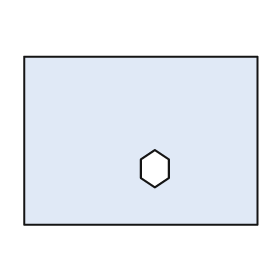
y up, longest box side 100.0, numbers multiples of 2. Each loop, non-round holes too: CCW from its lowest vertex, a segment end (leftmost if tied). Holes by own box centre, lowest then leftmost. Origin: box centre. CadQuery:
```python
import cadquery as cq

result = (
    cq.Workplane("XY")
    .moveTo(-50.0, -36.0)
    .lineTo(50.0, -36.0)
    .lineTo(50.0, 36.0)
    .lineTo(-50.0, 36.0)
    .close()
    .moveTo(6.0, -20.0)
    .lineTo(12.0, -16.0)
    .lineTo(12.0, -8.0)
    .lineTo(6.0, -4.0)
    .lineTo(0.0, -8.0)
    .lineTo(0.0, -16.0)
    .close()
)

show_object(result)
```